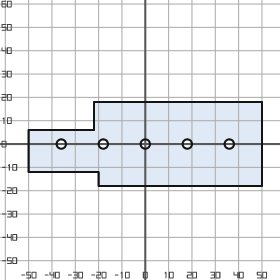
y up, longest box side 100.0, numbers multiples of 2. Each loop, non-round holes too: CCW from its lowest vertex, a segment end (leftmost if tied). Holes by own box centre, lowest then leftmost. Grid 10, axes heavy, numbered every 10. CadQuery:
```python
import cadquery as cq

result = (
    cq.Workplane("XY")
    .moveTo(-20.0, -18.0)
    .lineTo(50.0, -18.0)
    .lineTo(50.0, 18.0)
    .lineTo(-22.0, 18.0)
    .lineTo(-22.0, 6.0)
    .lineTo(-50.0, 6.0)
    .lineTo(-50.0, -12.0)
    .lineTo(-20.0, -12.0)
    .close()
    .moveTo(-36.0, 0.0)
    .circle(2.0)
    .moveTo(-18.0, 0.0)
    .circle(2.0)
    .moveTo(0.0, 0.0)
    .circle(2.0)
    .moveTo(18.0, 0.0)
    .circle(2.0)
    .moveTo(36.0, 0.0)
    .circle(2.0)
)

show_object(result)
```